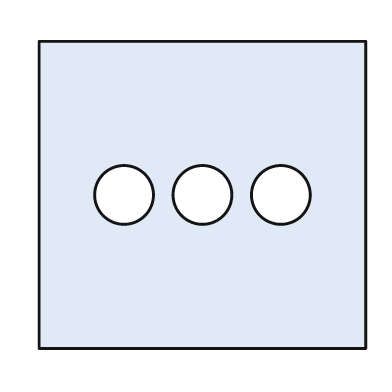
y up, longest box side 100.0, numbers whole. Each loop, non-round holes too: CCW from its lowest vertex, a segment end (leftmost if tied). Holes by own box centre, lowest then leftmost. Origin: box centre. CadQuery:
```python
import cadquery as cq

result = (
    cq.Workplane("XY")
    .moveTo(-50.0, -47.0)
    .lineTo(50.0, -47.0)
    .lineTo(50.0, 47.0)
    .lineTo(-50.0, 47.0)
    .close()
    .moveTo(-24.0, 0.0)
    .circle(9.0)
    .moveTo(0.0, 0.0)
    .circle(9.0)
    .moveTo(24.0, 0.0)
    .circle(9.0)
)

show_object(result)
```